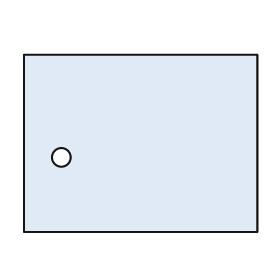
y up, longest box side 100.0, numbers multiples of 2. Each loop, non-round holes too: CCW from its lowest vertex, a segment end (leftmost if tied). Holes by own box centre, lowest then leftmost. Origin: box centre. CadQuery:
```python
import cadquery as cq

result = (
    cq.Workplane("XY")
    .moveTo(-50.0, -38.0)
    .lineTo(50.0, -38.0)
    .lineTo(50.0, 38.0)
    .lineTo(-50.0, 38.0)
    .close()
    .moveTo(-34.0, -6.0)
    .circle(4.0)
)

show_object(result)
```